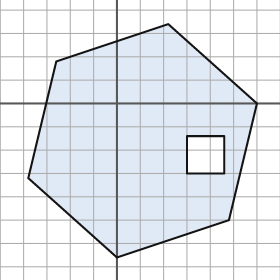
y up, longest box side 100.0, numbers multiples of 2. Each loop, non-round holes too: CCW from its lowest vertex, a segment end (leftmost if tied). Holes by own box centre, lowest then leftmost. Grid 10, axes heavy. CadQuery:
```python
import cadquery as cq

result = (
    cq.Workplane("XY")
    .moveTo(0.0, -66.0)
    .lineTo(48.0, -50.0)
    .lineTo(60.0, 0.0)
    .lineTo(22.0, 34.0)
    .lineTo(-26.0, 18.0)
    .lineTo(-38.0, -32.0)
    .close()
    .moveTo(30.0, -30.0)
    .lineTo(46.0, -30.0)
    .lineTo(46.0, -14.0)
    .lineTo(30.0, -14.0)
    .close()
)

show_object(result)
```